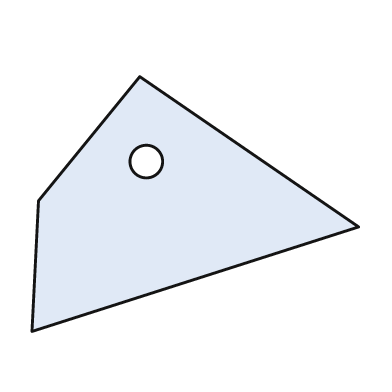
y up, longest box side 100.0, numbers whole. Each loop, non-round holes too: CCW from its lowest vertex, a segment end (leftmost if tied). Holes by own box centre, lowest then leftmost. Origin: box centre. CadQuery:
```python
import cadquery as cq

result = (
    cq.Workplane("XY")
    .moveTo(-50.0, -39.0)
    .lineTo(50.0, -7.0)
    .lineTo(-17.0, 39.0)
    .lineTo(-48.0, 1.0)
    .close()
    .moveTo(-15.0, 13.0)
    .circle(5.0)
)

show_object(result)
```